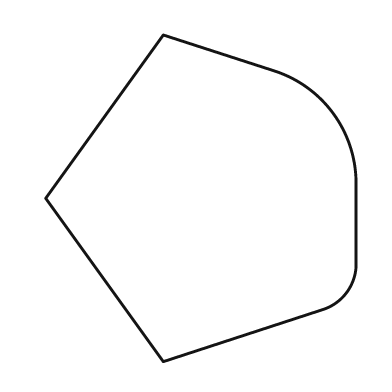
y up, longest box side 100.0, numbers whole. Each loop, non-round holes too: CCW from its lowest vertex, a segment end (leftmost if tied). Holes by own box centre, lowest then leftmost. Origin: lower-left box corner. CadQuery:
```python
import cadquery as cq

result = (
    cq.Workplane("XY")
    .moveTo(36.0, 0.0)
    .lineTo(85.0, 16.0)
    .threePointArc((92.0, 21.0), (95.0, 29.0))
    .lineTo(95.0, 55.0)
    .threePointArc((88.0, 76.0), (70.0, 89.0))
    .lineTo(36.0, 100.0)
    .lineTo(0.0, 50.0)
    .close()
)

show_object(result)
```